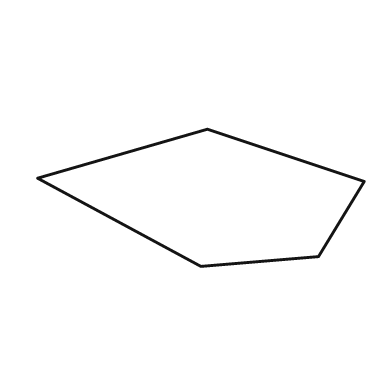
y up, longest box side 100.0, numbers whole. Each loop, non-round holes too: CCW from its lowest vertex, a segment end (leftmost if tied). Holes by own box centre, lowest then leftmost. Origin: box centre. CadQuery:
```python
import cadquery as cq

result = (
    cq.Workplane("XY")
    .moveTo(0.0, -21.0)
    .lineTo(36.0, -18.0)
    .lineTo(50.0, 5.0)
    .lineTo(2.0, 21.0)
    .lineTo(-50.0, 6.0)
    .close()
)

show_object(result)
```